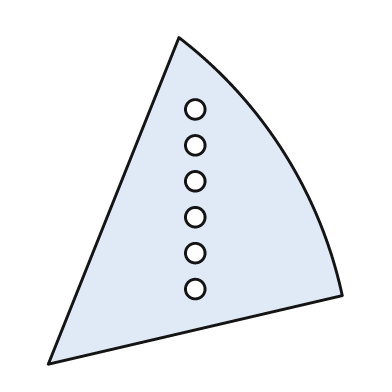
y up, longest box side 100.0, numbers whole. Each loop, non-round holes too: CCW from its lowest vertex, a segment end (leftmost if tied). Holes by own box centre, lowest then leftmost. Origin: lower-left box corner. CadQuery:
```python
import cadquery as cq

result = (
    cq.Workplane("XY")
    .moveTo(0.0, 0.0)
    .lineTo(90.0, 21.0)
    .threePointArc((72.0, 65.0), (40.0, 100.0))
    .close()
    .moveTo(45.0, 23.0)
    .circle(3.0)
    .moveTo(45.0, 34.0)
    .circle(3.0)
    .moveTo(45.0, 45.0)
    .circle(3.0)
    .moveTo(45.0, 56.0)
    .circle(3.0)
    .moveTo(45.0, 67.0)
    .circle(3.0)
    .moveTo(45.0, 78.0)
    .circle(3.0)
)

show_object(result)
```